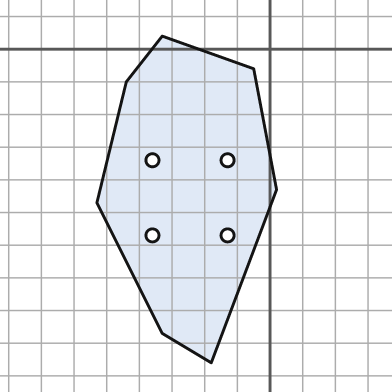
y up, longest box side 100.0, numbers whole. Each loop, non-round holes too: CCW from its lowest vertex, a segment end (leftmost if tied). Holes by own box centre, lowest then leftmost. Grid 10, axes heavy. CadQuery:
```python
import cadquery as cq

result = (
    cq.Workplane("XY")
    .moveTo(-18.0, -96.0)
    .lineTo(2.0, -43.0)
    .lineTo(-5.0, -6.0)
    .lineTo(-33.0, 4.0)
    .lineTo(-44.0, -10.0)
    .lineTo(-53.0, -47.0)
    .lineTo(-33.0, -87.0)
    .close()
    .moveTo(-36.0, -57.0)
    .circle(2.0)
    .moveTo(-13.0, -57.0)
    .circle(2.0)
    .moveTo(-36.0, -34.0)
    .circle(2.0)
    .moveTo(-13.0, -34.0)
    .circle(2.0)
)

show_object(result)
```